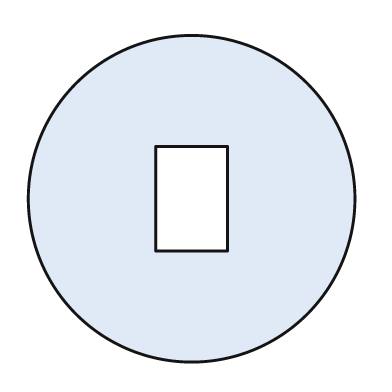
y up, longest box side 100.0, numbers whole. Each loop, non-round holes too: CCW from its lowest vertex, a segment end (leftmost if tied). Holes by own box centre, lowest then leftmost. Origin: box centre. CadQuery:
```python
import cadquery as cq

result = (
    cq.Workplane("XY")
    .moveTo(0.0, 0.0)
    .circle(50.0)
    .moveTo(-11.0, -16.0)
    .lineTo(11.0, -16.0)
    .lineTo(11.0, 16.0)
    .lineTo(-11.0, 16.0)
    .close()
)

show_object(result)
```